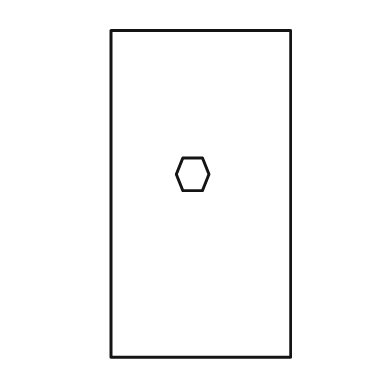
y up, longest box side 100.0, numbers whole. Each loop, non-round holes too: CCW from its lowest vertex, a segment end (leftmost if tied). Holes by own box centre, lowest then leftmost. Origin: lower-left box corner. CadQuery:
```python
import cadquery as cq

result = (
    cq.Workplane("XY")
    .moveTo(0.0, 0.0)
    .lineTo(55.0, 0.0)
    .lineTo(55.0, 100.0)
    .lineTo(0.0, 100.0)
    .close()
    .moveTo(22.0, 51.0)
    .lineTo(28.0, 51.0)
    .lineTo(30.0, 56.0)
    .lineTo(28.0, 61.0)
    .lineTo(22.0, 61.0)
    .lineTo(20.0, 56.0)
    .close()
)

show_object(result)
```